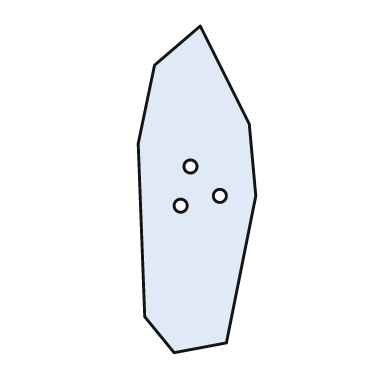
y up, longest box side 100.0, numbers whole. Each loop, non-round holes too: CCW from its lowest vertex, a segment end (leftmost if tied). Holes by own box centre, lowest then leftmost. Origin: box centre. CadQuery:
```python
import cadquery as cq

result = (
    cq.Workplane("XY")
    .moveTo(-7.0, -50.0)
    .lineTo(9.0, -47.0)
    .lineTo(18.0, -2.0)
    .lineTo(16.0, 20.0)
    .lineTo(1.0, 50.0)
    .lineTo(-13.0, 38.0)
    .lineTo(-18.0, 14.0)
    .lineTo(-16.0, -39.0)
    .close()
    .moveTo(-5.0, -5.0)
    .circle(2.0)
    .moveTo(7.0, -2.0)
    .circle(2.0)
    .moveTo(-2.0, 7.0)
    .circle(2.0)
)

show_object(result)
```